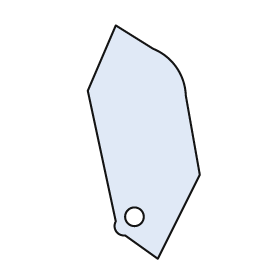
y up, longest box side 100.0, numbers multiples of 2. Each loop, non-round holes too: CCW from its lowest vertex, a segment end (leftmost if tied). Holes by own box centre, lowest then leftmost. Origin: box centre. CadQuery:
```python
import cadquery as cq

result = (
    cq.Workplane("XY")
    .moveTo(6.0, -50.0)
    .lineTo(24.0, -14.0)
    .lineTo(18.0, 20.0)
    .threePointArc((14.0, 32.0), (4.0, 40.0))
    .lineTo(-12.0, 50.0)
    .lineTo(-24.0, 22.0)
    .lineTo(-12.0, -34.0)
    .threePointArc((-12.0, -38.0), (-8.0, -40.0))
    .close()
    .moveTo(-4.0, -32.0)
    .circle(4.0)
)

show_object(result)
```